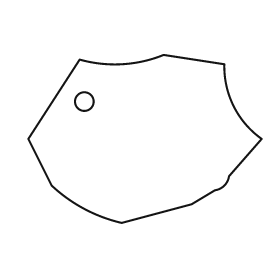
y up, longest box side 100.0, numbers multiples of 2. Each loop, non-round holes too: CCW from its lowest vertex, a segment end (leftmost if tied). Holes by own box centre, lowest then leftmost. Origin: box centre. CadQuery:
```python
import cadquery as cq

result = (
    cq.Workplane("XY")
    .moveTo(-10.0, -36.0)
    .lineTo(20.0, -28.0)
    .lineTo(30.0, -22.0)
    .threePointArc((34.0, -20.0), (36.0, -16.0))
    .lineTo(50.0, 0.0)
    .threePointArc((38.0, 14.0), (34.0, 32.0))
    .lineTo(8.0, 36.0)
    .threePointArc((-10.0, 32.0), (-28.0, 34.0))
    .lineTo(-50.0, 0.0)
    .lineTo(-40.0, -20.0)
    .threePointArc((-26.0, -30.0), (-10.0, -36.0))
    .close()
    .moveTo(-26.0, 16.0)
    .circle(4.0)
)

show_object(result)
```